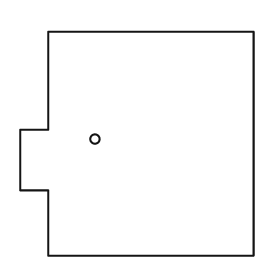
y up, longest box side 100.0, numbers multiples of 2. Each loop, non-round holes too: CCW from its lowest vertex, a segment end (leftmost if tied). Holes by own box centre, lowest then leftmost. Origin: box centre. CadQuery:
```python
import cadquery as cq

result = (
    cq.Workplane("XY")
    .moveTo(-38.0, -48.0)
    .lineTo(50.0, -48.0)
    .lineTo(50.0, 48.0)
    .lineTo(-38.0, 48.0)
    .lineTo(-38.0, 6.0)
    .lineTo(-50.0, 6.0)
    .lineTo(-50.0, -20.0)
    .lineTo(-38.0, -20.0)
    .close()
    .moveTo(-18.0, 2.0)
    .circle(2.0)
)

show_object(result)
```